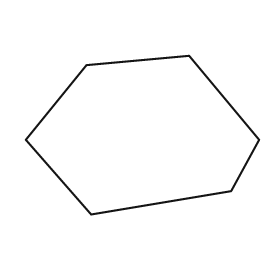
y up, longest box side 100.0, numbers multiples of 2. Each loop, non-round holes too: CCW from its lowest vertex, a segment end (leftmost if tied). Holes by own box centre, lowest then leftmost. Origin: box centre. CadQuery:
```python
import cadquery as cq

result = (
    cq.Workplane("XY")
    .moveTo(-22.0, -34.0)
    .lineTo(38.0, -24.0)
    .lineTo(50.0, -2.0)
    .lineTo(20.0, 34.0)
    .lineTo(-24.0, 30.0)
    .lineTo(-50.0, -2.0)
    .close()
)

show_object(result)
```